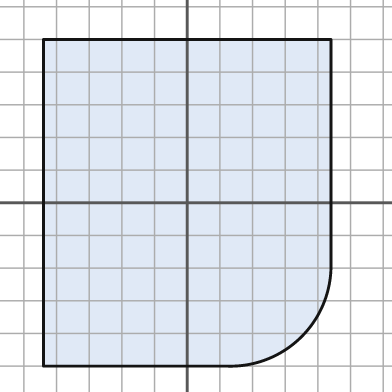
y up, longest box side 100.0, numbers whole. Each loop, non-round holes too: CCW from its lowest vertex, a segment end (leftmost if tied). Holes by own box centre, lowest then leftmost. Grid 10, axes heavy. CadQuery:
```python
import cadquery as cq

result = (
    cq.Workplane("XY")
    .moveTo(-44.0, -50.0)
    .lineTo(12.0, -50.0)
    .threePointArc((35.0, -41.0), (44.0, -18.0))
    .lineTo(44.0, 50.0)
    .lineTo(-44.0, 50.0)
    .close()
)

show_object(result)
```